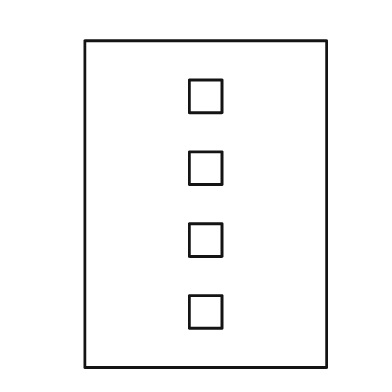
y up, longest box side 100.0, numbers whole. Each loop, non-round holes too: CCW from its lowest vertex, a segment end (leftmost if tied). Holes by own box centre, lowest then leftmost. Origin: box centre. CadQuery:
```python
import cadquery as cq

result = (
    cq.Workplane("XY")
    .moveTo(-37.0, -50.0)
    .lineTo(37.0, -50.0)
    .lineTo(37.0, 50.0)
    .lineTo(-37.0, 50.0)
    .close()
    .moveTo(-5.0, -38.0)
    .lineTo(5.0, -38.0)
    .lineTo(5.0, -28.0)
    .lineTo(-5.0, -28.0)
    .close()
    .moveTo(-5.0, -16.0)
    .lineTo(5.0, -16.0)
    .lineTo(5.0, -6.0)
    .lineTo(-5.0, -6.0)
    .close()
    .moveTo(-5.0, 6.0)
    .lineTo(5.0, 6.0)
    .lineTo(5.0, 16.0)
    .lineTo(-5.0, 16.0)
    .close()
    .moveTo(-5.0, 28.0)
    .lineTo(5.0, 28.0)
    .lineTo(5.0, 38.0)
    .lineTo(-5.0, 38.0)
    .close()
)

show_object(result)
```